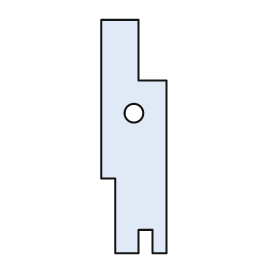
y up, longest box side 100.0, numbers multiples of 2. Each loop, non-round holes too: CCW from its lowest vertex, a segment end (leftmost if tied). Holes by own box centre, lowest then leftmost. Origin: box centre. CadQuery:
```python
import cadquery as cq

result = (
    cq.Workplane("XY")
    .moveTo(-8.0, -50.0)
    .lineTo(2.0, -50.0)
    .lineTo(2.0, -40.0)
    .lineTo(8.0, -40.0)
    .lineTo(8.0, -50.0)
    .lineTo(14.0, -50.0)
    .lineTo(14.0, 24.0)
    .lineTo(2.0, 24.0)
    .lineTo(2.0, 50.0)
    .lineTo(-14.0, 50.0)
    .lineTo(-14.0, -18.0)
    .lineTo(-8.0, -18.0)
    .close()
    .moveTo(0.0, 10.0)
    .circle(4.0)
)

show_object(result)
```